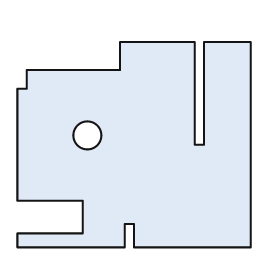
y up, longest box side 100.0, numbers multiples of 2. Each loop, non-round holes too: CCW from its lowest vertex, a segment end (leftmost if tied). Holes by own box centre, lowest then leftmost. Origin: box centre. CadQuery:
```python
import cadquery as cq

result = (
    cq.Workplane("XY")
    .moveTo(-50.0, -44.0)
    .lineTo(-4.0, -44.0)
    .lineTo(-4.0, -34.0)
    .lineTo(0.0, -34.0)
    .lineTo(0.0, -44.0)
    .lineTo(50.0, -44.0)
    .lineTo(50.0, 44.0)
    .lineTo(30.0, 44.0)
    .lineTo(30.0, 0.0)
    .lineTo(26.0, 0.0)
    .lineTo(26.0, 44.0)
    .lineTo(-6.0, 44.0)
    .lineTo(-6.0, 32.0)
    .lineTo(-46.0, 32.0)
    .lineTo(-46.0, 24.0)
    .lineTo(-50.0, 24.0)
    .lineTo(-50.0, -24.0)
    .lineTo(-22.0, -24.0)
    .lineTo(-22.0, -38.0)
    .lineTo(-50.0, -38.0)
    .close()
    .moveTo(-20.0, 4.0)
    .circle(6.0)
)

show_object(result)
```